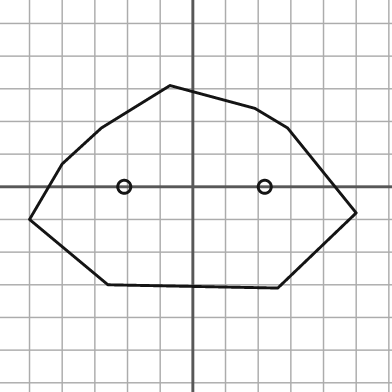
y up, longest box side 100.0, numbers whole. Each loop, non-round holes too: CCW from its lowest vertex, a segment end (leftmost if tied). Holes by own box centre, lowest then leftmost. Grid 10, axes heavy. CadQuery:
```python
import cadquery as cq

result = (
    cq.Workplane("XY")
    .moveTo(26.0, -31.0)
    .lineTo(50.0, -8.0)
    .lineTo(29.0, 18.0)
    .lineTo(19.0, 24.0)
    .lineTo(-7.0, 31.0)
    .lineTo(-28.0, 18.0)
    .lineTo(-40.0, 7.0)
    .lineTo(-50.0, -10.0)
    .lineTo(-26.0, -30.0)
    .close()
    .moveTo(-21.0, 0.0)
    .circle(2.0)
    .moveTo(22.0, 0.0)
    .circle(2.0)
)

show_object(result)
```